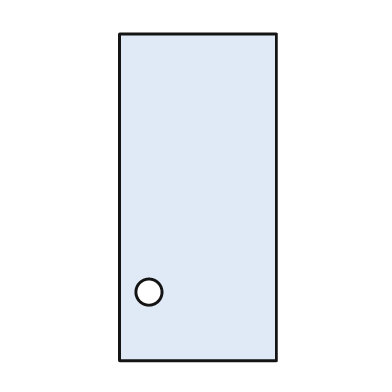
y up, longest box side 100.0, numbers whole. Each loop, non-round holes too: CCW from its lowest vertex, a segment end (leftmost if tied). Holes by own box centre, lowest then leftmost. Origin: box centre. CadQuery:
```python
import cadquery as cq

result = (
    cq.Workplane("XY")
    .moveTo(-24.0, -50.0)
    .lineTo(24.0, -50.0)
    .lineTo(24.0, 50.0)
    .lineTo(-24.0, 50.0)
    .close()
    .moveTo(-15.0, -29.0)
    .circle(4.0)
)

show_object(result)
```